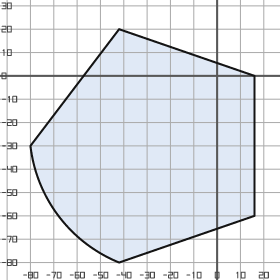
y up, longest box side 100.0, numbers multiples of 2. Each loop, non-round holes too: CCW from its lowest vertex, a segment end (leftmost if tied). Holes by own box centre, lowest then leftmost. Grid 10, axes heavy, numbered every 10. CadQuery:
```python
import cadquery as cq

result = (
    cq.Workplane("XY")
    .moveTo(-42.0, -80.0)
    .lineTo(16.0, -60.0)
    .lineTo(16.0, 0.0)
    .lineTo(-42.0, 20.0)
    .lineTo(-80.0, -30.0)
    .threePointArc((-68.0, -60.0), (-42.0, -80.0))
    .close()
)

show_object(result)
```